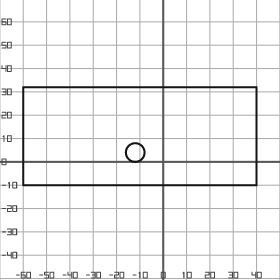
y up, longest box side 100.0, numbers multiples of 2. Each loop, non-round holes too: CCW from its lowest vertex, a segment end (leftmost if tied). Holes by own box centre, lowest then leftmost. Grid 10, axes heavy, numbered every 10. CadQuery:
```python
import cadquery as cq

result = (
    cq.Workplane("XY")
    .moveTo(-60.0, -10.0)
    .lineTo(40.0, -10.0)
    .lineTo(40.0, 32.0)
    .lineTo(-60.0, 32.0)
    .close()
    .moveTo(-12.0, 4.0)
    .circle(4.0)
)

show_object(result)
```